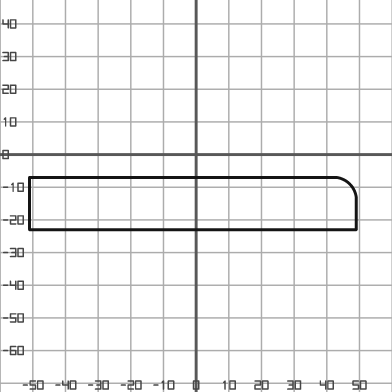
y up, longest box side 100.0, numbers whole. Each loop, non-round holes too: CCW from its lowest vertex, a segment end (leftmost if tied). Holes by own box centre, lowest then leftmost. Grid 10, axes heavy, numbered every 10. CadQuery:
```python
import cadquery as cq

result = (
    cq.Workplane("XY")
    .moveTo(-51.0, -23.0)
    .lineTo(49.0, -23.0)
    .lineTo(49.0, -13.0)
    .threePointArc((47.0, -9.0), (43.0, -7.0))
    .lineTo(-51.0, -7.0)
    .close()
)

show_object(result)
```